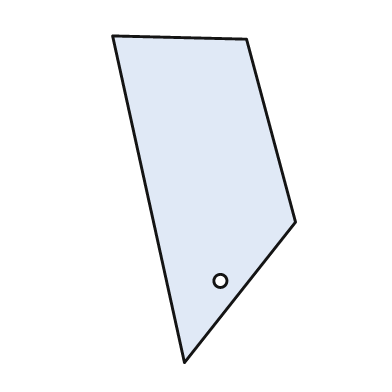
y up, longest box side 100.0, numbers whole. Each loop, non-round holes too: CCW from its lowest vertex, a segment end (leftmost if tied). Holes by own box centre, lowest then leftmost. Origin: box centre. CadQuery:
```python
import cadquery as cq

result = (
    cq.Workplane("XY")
    .moveTo(-6.0, -50.0)
    .lineTo(28.0, -7.0)
    .lineTo(13.0, 49.0)
    .lineTo(-28.0, 50.0)
    .close()
    .moveTo(5.0, -25.0)
    .circle(2.0)
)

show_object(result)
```